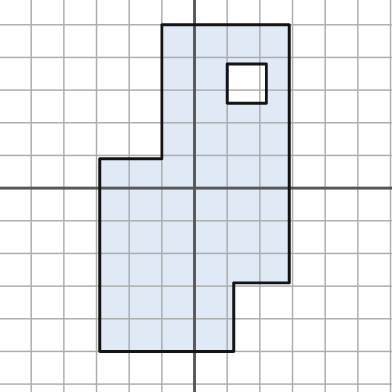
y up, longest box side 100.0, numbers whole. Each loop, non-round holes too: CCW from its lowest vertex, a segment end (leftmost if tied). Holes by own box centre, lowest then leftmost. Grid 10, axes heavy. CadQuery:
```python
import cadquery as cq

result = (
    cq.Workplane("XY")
    .moveTo(-29.0, -50.0)
    .lineTo(12.0, -50.0)
    .lineTo(12.0, -29.0)
    .lineTo(29.0, -29.0)
    .lineTo(29.0, 50.0)
    .lineTo(-10.0, 50.0)
    .lineTo(-10.0, 9.0)
    .lineTo(-29.0, 9.0)
    .close()
    .moveTo(10.0, 26.0)
    .lineTo(22.0, 26.0)
    .lineTo(22.0, 38.0)
    .lineTo(10.0, 38.0)
    .close()
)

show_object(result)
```